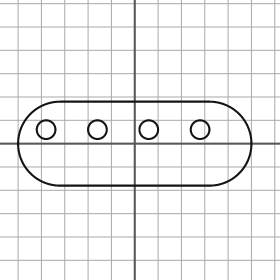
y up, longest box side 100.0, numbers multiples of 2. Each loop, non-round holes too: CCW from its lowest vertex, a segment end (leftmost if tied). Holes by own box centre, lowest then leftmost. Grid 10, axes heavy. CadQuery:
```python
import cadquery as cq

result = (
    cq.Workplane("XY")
    .moveTo(-32.0, -18.0)
    .lineTo(32.0, -18.0)
    .threePointArc((50.0, 0.0), (32.0, 18.0))
    .lineTo(-32.0, 18.0)
    .threePointArc((-50.0, 0.0), (-32.0, -18.0))
    .close()
    .moveTo(-38.0, 6.0)
    .circle(4.0)
    .moveTo(-16.0, 6.0)
    .circle(4.0)
    .moveTo(6.0, 6.0)
    .circle(4.0)
    .moveTo(28.0, 6.0)
    .circle(4.0)
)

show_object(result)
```